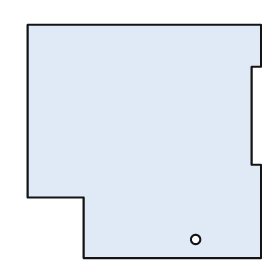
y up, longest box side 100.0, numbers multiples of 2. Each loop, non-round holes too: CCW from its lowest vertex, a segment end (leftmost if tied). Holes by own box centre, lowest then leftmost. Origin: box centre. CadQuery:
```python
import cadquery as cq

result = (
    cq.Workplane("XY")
    .moveTo(-26.0, -50.0)
    .lineTo(50.0, -50.0)
    .lineTo(50.0, -10.0)
    .lineTo(46.0, -10.0)
    .lineTo(46.0, 32.0)
    .lineTo(50.0, 32.0)
    .lineTo(50.0, 50.0)
    .lineTo(-50.0, 50.0)
    .lineTo(-50.0, -24.0)
    .lineTo(-26.0, -24.0)
    .close()
    .moveTo(22.0, -42.0)
    .circle(2.0)
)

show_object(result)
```